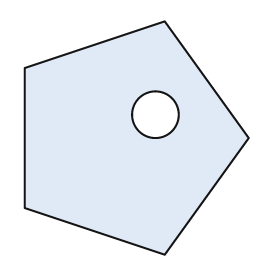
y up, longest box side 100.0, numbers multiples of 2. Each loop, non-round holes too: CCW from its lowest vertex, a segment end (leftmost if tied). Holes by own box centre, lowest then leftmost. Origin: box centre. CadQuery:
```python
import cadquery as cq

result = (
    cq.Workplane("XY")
    .moveTo(12.0, -50.0)
    .lineTo(48.0, 0.0)
    .lineTo(12.0, 50.0)
    .lineTo(-48.0, 30.0)
    .lineTo(-48.0, -30.0)
    .close()
    .moveTo(8.0, 10.0)
    .circle(10.0)
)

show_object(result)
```